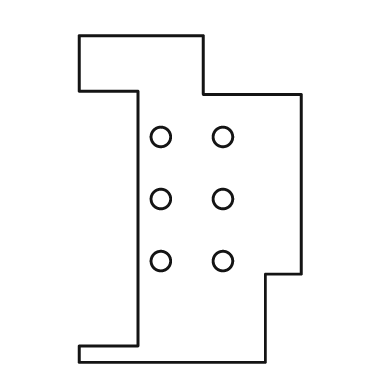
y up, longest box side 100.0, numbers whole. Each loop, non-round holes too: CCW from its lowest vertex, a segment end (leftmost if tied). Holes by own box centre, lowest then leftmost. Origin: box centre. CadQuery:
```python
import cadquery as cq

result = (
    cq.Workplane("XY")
    .moveTo(-34.0, -50.0)
    .lineTo(23.0, -50.0)
    .lineTo(23.0, -23.0)
    .lineTo(34.0, -23.0)
    .lineTo(34.0, 32.0)
    .lineTo(4.0, 32.0)
    .lineTo(4.0, 50.0)
    .lineTo(-34.0, 50.0)
    .lineTo(-34.0, 33.0)
    .lineTo(-16.0, 33.0)
    .lineTo(-16.0, -45.0)
    .lineTo(-34.0, -45.0)
    .close()
    .moveTo(-9.0, -19.0)
    .circle(3.0)
    .moveTo(10.0, -19.0)
    .circle(3.0)
    .moveTo(-9.0, 0.0)
    .circle(3.0)
    .moveTo(10.0, 0.0)
    .circle(3.0)
    .moveTo(-9.0, 19.0)
    .circle(3.0)
    .moveTo(10.0, 19.0)
    .circle(3.0)
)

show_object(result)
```